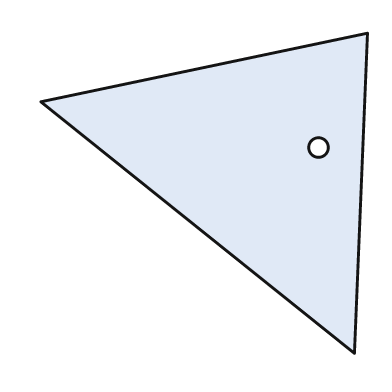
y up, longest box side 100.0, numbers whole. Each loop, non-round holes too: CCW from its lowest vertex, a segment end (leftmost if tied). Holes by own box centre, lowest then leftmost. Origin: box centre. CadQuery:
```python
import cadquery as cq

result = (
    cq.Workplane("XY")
    .moveTo(46.0, -49.0)
    .lineTo(50.0, 49.0)
    .lineTo(-50.0, 28.0)
    .close()
    .moveTo(35.0, 14.0)
    .circle(3.0)
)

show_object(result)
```